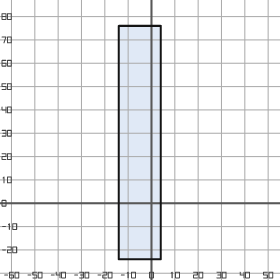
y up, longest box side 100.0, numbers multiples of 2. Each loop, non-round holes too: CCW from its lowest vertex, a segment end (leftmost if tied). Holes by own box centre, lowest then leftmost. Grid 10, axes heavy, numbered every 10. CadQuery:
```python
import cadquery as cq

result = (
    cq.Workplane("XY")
    .moveTo(-14.0, -24.0)
    .lineTo(4.0, -24.0)
    .lineTo(4.0, 76.0)
    .lineTo(-14.0, 76.0)
    .close()
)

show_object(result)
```